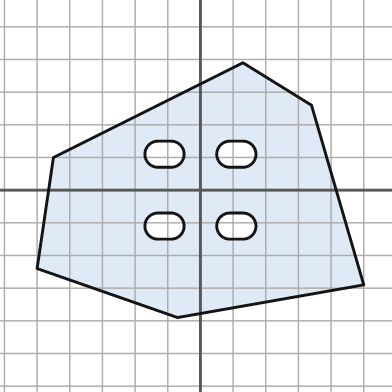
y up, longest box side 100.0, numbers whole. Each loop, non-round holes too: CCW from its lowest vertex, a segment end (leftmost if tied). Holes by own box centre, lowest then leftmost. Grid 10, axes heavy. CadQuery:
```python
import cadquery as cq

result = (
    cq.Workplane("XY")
    .moveTo(-7.0, -39.0)
    .lineTo(50.0, -29.0)
    .lineTo(34.0, 26.0)
    .lineTo(13.0, 39.0)
    .lineTo(-45.0, 10.0)
    .lineTo(-50.0, -24.0)
    .close()
    .moveTo(-13.0, -15.0)
    .lineTo(-9.0, -15.0)
    .threePointArc((-5.0, -11.0), (-9.0, -7.0))
    .lineTo(-13.0, -7.0)
    .threePointArc((-17.0, -11.0), (-13.0, -15.0))
    .close()
    .moveTo(9.0, -15.0)
    .lineTo(13.0, -15.0)
    .threePointArc((17.0, -11.0), (13.0, -7.0))
    .lineTo(9.0, -7.0)
    .threePointArc((5.0, -11.0), (9.0, -15.0))
    .close()
    .moveTo(-13.0, 7.0)
    .lineTo(-9.0, 7.0)
    .threePointArc((-5.0, 11.0), (-9.0, 15.0))
    .lineTo(-13.0, 15.0)
    .threePointArc((-17.0, 11.0), (-13.0, 7.0))
    .close()
    .moveTo(9.0, 7.0)
    .lineTo(13.0, 7.0)
    .threePointArc((17.0, 11.0), (13.0, 15.0))
    .lineTo(9.0, 15.0)
    .threePointArc((5.0, 11.0), (9.0, 7.0))
    .close()
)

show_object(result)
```